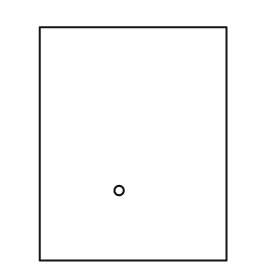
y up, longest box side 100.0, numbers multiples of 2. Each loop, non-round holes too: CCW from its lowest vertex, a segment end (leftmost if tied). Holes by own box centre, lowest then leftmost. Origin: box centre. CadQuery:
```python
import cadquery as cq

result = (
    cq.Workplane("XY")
    .moveTo(-40.0, -50.0)
    .lineTo(40.0, -50.0)
    .lineTo(40.0, 50.0)
    .lineTo(-40.0, 50.0)
    .close()
    .moveTo(-6.0, -20.0)
    .circle(2.0)
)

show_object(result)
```